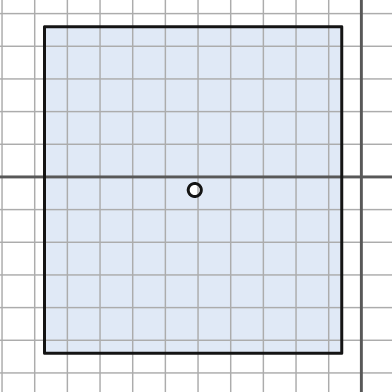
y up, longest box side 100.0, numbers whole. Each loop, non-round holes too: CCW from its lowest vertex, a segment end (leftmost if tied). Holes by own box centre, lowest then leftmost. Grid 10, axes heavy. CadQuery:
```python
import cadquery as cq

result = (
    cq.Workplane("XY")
    .moveTo(-97.0, -54.0)
    .lineTo(-6.0, -54.0)
    .lineTo(-6.0, 46.0)
    .lineTo(-97.0, 46.0)
    .close()
    .moveTo(-51.0, -4.0)
    .circle(2.0)
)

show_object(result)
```